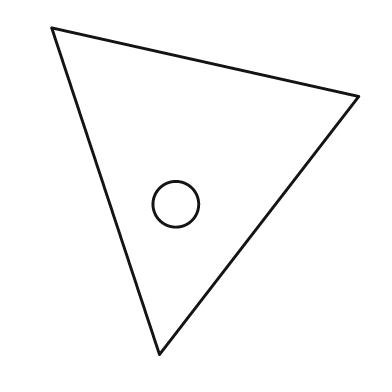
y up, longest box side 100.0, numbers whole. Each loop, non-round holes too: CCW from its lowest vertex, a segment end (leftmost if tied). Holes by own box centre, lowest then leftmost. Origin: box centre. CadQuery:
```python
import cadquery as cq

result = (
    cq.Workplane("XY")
    .moveTo(-14.0, -50.0)
    .lineTo(47.0, 29.0)
    .lineTo(-47.0, 50.0)
    .close()
    .moveTo(-9.0, -4.0)
    .circle(7.0)
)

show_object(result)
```